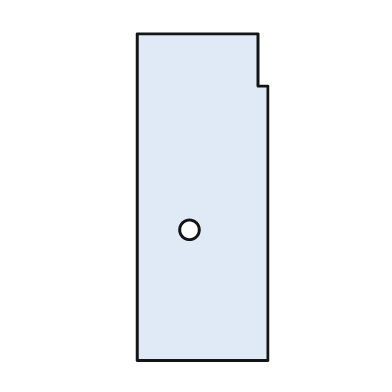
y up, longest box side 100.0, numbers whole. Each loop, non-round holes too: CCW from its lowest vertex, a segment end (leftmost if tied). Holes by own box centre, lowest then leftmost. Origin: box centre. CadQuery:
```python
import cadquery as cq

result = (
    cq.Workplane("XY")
    .moveTo(-20.0, -50.0)
    .lineTo(20.0, -50.0)
    .lineTo(20.0, 34.0)
    .lineTo(17.0, 34.0)
    .lineTo(17.0, 50.0)
    .lineTo(-20.0, 50.0)
    .close()
    .moveTo(-4.0, -10.0)
    .circle(3.0)
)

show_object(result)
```